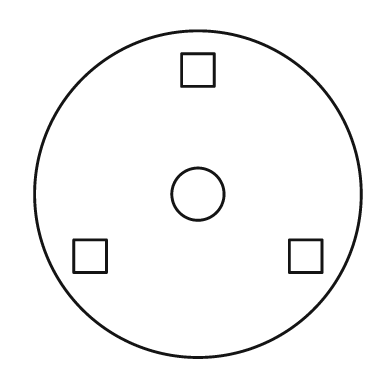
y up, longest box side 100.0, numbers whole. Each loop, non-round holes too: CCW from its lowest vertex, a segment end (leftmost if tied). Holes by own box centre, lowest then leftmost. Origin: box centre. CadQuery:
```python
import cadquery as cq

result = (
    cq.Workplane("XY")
    .moveTo(0.0, 0.0)
    .circle(50.0)
    .moveTo(-38.0, -24.0)
    .lineTo(-28.0, -24.0)
    .lineTo(-28.0, -14.0)
    .lineTo(-38.0, -14.0)
    .close()
    .moveTo(28.0, -24.0)
    .lineTo(38.0, -24.0)
    .lineTo(38.0, -14.0)
    .lineTo(28.0, -14.0)
    .close()
    .moveTo(0.0, 0.0)
    .circle(8.0)
    .moveTo(-5.0, 33.0)
    .lineTo(5.0, 33.0)
    .lineTo(5.0, 43.0)
    .lineTo(-5.0, 43.0)
    .close()
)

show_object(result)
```